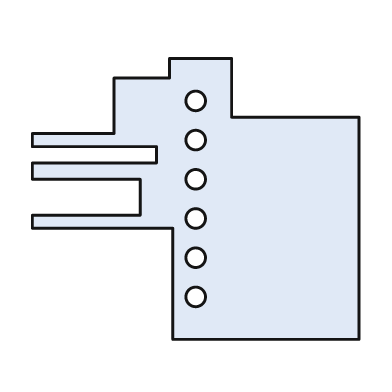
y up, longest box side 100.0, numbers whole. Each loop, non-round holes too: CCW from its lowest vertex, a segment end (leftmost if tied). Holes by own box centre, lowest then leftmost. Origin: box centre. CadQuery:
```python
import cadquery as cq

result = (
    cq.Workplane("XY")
    .moveTo(-7.0, -43.0)
    .lineTo(50.0, -43.0)
    .lineTo(50.0, 25.0)
    .lineTo(11.0, 25.0)
    .lineTo(11.0, 43.0)
    .lineTo(-8.0, 43.0)
    .lineTo(-8.0, 37.0)
    .lineTo(-25.0, 37.0)
    .lineTo(-25.0, 20.0)
    .lineTo(-50.0, 20.0)
    .lineTo(-50.0, 16.0)
    .lineTo(-12.0, 16.0)
    .lineTo(-12.0, 11.0)
    .lineTo(-50.0, 11.0)
    .lineTo(-50.0, 6.0)
    .lineTo(-17.0, 6.0)
    .lineTo(-17.0, -5.0)
    .lineTo(-50.0, -5.0)
    .lineTo(-50.0, -9.0)
    .lineTo(-7.0, -9.0)
    .close()
    .moveTo(0.0, -30.0)
    .circle(3.0)
    .moveTo(0.0, -18.0)
    .circle(3.0)
    .moveTo(0.0, -6.0)
    .circle(3.0)
    .moveTo(0.0, 6.0)
    .circle(3.0)
    .moveTo(0.0, 18.0)
    .circle(3.0)
    .moveTo(0.0, 30.0)
    .circle(3.0)
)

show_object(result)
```